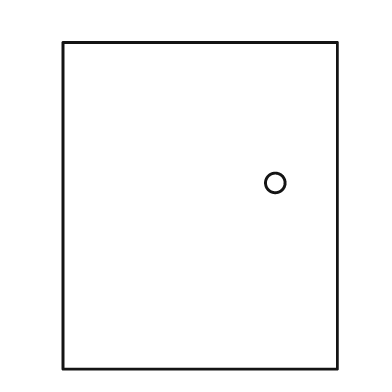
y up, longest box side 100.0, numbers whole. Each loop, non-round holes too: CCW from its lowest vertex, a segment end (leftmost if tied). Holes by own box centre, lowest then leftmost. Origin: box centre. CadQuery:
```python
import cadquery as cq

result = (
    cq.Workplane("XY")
    .moveTo(-42.0, -50.0)
    .lineTo(42.0, -50.0)
    .lineTo(42.0, 50.0)
    .lineTo(-42.0, 50.0)
    .close()
    .moveTo(23.0, 7.0)
    .circle(3.0)
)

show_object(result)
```